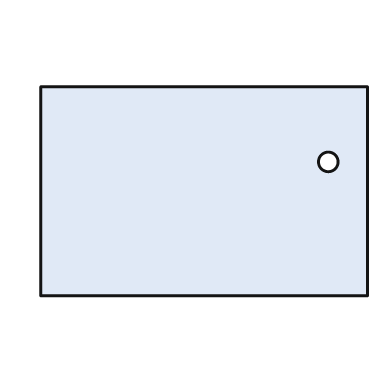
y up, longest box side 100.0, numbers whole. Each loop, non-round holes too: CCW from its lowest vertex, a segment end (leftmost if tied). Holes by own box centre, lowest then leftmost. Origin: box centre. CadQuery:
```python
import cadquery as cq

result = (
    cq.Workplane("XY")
    .moveTo(-50.0, -32.0)
    .lineTo(50.0, -32.0)
    .lineTo(50.0, 32.0)
    .lineTo(-50.0, 32.0)
    .close()
    .moveTo(38.0, 9.0)
    .circle(3.0)
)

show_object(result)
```